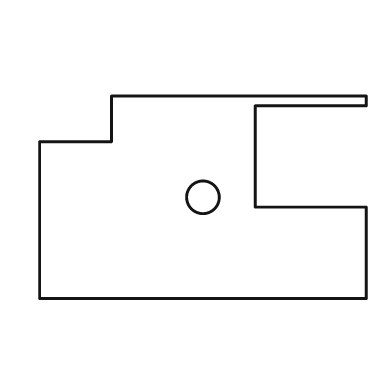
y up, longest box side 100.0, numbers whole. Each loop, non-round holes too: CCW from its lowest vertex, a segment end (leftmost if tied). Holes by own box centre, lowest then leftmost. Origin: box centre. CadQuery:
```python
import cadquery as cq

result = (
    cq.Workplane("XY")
    .moveTo(-50.0, -31.0)
    .lineTo(50.0, -31.0)
    .lineTo(50.0, -3.0)
    .lineTo(16.0, -3.0)
    .lineTo(16.0, 28.0)
    .lineTo(50.0, 28.0)
    .lineTo(50.0, 31.0)
    .lineTo(-28.0, 31.0)
    .lineTo(-28.0, 17.0)
    .lineTo(-50.0, 17.0)
    .close()
    .moveTo(0.0, 0.0)
    .circle(5.0)
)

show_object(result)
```